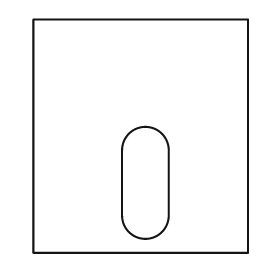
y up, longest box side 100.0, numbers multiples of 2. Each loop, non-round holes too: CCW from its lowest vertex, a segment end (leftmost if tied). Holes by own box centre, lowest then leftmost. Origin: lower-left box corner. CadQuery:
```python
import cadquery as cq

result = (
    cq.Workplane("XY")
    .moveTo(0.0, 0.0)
    .lineTo(92.0, 0.0)
    .lineTo(92.0, 100.0)
    .lineTo(0.0, 100.0)
    .close()
    .moveTo(38.0, 16.0)
    .threePointArc((48.0, 6.0), (58.0, 16.0))
    .lineTo(58.0, 44.0)
    .threePointArc((48.0, 54.0), (38.0, 44.0))
    .close()
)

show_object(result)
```